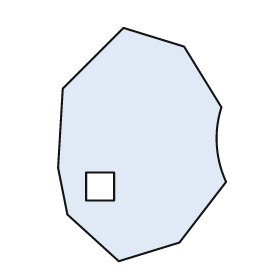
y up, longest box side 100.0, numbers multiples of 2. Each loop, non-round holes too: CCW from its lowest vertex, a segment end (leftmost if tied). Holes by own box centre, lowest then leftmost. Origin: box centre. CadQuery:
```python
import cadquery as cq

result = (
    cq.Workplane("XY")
    .moveTo(-10.0, -50.0)
    .lineTo(16.0, -42.0)
    .lineTo(36.0, -16.0)
    .threePointArc((32.0, 0.0), (34.0, 16.0))
    .lineTo(18.0, 42.0)
    .lineTo(-8.0, 50.0)
    .lineTo(-34.0, 24.0)
    .lineTo(-36.0, -10.0)
    .lineTo(-32.0, -30.0)
    .close()
    .moveTo(-24.0, -24.0)
    .lineTo(-12.0, -24.0)
    .lineTo(-12.0, -12.0)
    .lineTo(-24.0, -12.0)
    .close()
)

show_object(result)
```